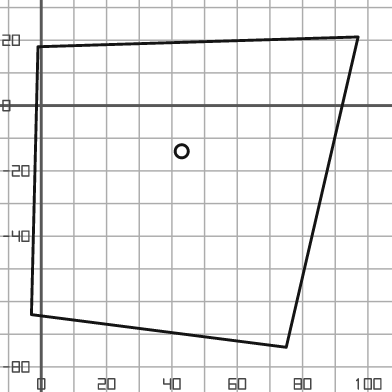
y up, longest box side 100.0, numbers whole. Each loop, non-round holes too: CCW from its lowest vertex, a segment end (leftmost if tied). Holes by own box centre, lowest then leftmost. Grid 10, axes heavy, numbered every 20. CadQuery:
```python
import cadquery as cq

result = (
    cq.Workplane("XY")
    .moveTo(75.0, -74.0)
    .lineTo(97.0, 21.0)
    .lineTo(-1.0, 18.0)
    .lineTo(-3.0, -64.0)
    .close()
    .moveTo(43.0, -14.0)
    .circle(2.0)
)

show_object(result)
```